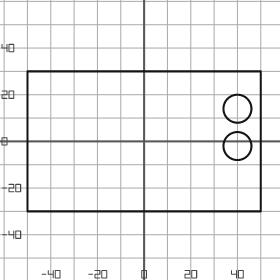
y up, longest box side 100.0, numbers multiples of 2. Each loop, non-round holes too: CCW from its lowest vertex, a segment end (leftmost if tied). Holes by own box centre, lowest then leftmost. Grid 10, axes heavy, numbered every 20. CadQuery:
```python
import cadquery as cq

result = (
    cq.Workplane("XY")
    .moveTo(-50.0, -30.0)
    .lineTo(50.0, -30.0)
    .lineTo(50.0, 30.0)
    .lineTo(-50.0, 30.0)
    .close()
    .moveTo(40.0, -2.0)
    .circle(6.0)
    .moveTo(40.0, 14.0)
    .circle(6.0)
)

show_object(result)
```